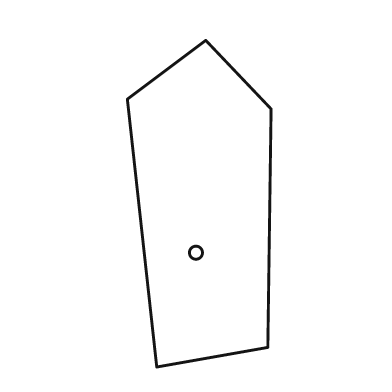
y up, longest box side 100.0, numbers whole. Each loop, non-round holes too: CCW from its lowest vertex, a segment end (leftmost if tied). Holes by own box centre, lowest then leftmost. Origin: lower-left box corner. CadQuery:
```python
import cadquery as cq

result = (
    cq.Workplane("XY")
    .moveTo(9.0, 0.0)
    .lineTo(43.0, 6.0)
    .lineTo(44.0, 79.0)
    .lineTo(24.0, 100.0)
    .lineTo(0.0, 82.0)
    .close()
    .moveTo(21.0, 35.0)
    .circle(2.0)
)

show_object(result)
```